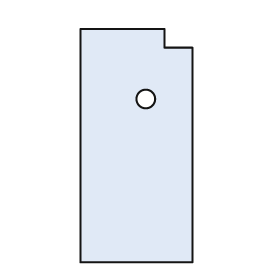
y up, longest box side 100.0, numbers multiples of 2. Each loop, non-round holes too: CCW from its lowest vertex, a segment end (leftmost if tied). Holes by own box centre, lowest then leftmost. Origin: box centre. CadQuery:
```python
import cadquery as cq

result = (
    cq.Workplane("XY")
    .moveTo(-24.0, -50.0)
    .lineTo(24.0, -50.0)
    .lineTo(24.0, 42.0)
    .lineTo(12.0, 42.0)
    .lineTo(12.0, 50.0)
    .lineTo(-24.0, 50.0)
    .close()
    .moveTo(4.0, 20.0)
    .circle(4.0)
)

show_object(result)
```